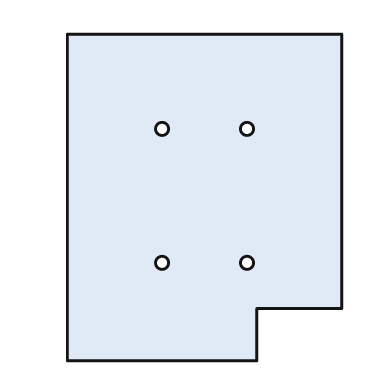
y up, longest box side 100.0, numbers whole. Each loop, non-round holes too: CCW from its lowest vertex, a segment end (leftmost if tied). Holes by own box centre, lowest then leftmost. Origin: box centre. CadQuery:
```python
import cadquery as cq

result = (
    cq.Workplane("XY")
    .moveTo(-42.0, -50.0)
    .lineTo(16.0, -50.0)
    .lineTo(16.0, -34.0)
    .lineTo(42.0, -34.0)
    .lineTo(42.0, 50.0)
    .lineTo(-42.0, 50.0)
    .close()
    .moveTo(-13.0, -20.0)
    .circle(2.0)
    .moveTo(13.0, -20.0)
    .circle(2.0)
    .moveTo(-13.0, 21.0)
    .circle(2.0)
    .moveTo(13.0, 21.0)
    .circle(2.0)
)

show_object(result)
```